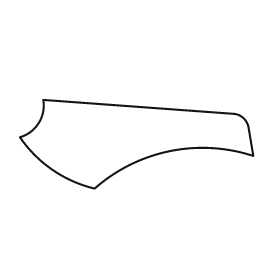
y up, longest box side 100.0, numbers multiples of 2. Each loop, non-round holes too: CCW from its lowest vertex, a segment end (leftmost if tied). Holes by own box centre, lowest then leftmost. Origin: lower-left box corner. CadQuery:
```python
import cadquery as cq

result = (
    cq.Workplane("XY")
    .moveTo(32.0, 0.0)
    .threePointArc((64.0, 16.0), (100.0, 14.0))
    .lineTo(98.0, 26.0)
    .threePointArc((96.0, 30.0), (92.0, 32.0))
    .lineTo(10.0, 38.0)
    .threePointArc((8.0, 28.0), (0.0, 22.0))
    .threePointArc((14.0, 8.0), (32.0, 0.0))
    .close()
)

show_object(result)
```